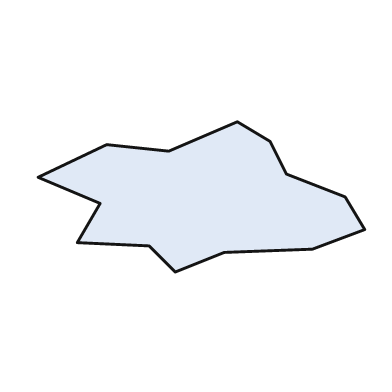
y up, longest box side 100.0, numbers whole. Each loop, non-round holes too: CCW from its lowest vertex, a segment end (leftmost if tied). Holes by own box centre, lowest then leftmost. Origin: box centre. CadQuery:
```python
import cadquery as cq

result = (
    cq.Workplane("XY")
    .moveTo(-8.0, -23.0)
    .lineTo(7.0, -17.0)
    .lineTo(34.0, -16.0)
    .lineTo(50.0, -10.0)
    .lineTo(44.0, 0.0)
    .lineTo(26.0, 7.0)
    .lineTo(21.0, 17.0)
    .lineTo(11.0, 23.0)
    .lineTo(-10.0, 14.0)
    .lineTo(-29.0, 16.0)
    .lineTo(-50.0, 6.0)
    .lineTo(-31.0, -2.0)
    .lineTo(-38.0, -14.0)
    .lineTo(-16.0, -15.0)
    .close()
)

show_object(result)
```